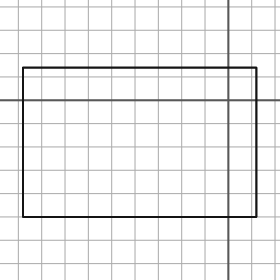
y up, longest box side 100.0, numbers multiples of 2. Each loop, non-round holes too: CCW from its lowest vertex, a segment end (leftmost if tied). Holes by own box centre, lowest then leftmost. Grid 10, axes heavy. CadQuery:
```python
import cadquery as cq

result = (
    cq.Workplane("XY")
    .moveTo(-88.0, -50.0)
    .lineTo(12.0, -50.0)
    .lineTo(12.0, 14.0)
    .lineTo(-88.0, 14.0)
    .close()
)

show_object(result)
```